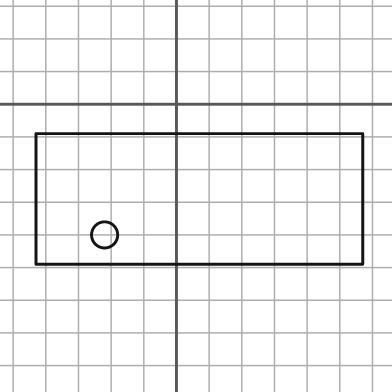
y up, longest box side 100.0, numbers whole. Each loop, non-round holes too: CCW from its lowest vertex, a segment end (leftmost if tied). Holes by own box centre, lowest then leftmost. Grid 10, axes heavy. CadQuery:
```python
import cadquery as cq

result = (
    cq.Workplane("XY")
    .moveTo(-43.0, -49.0)
    .lineTo(57.0, -49.0)
    .lineTo(57.0, -9.0)
    .lineTo(-43.0, -9.0)
    .close()
    .moveTo(-22.0, -40.0)
    .circle(4.0)
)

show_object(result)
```